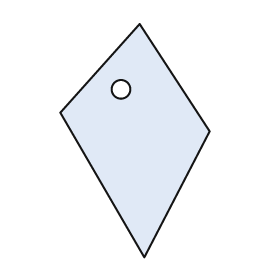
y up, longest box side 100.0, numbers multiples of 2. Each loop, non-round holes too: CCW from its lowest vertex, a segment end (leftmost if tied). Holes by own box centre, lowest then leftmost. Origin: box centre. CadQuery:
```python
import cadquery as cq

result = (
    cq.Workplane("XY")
    .moveTo(4.0, -50.0)
    .lineTo(32.0, 4.0)
    .lineTo(2.0, 50.0)
    .lineTo(-32.0, 12.0)
    .close()
    .moveTo(-6.0, 22.0)
    .circle(4.0)
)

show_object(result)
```